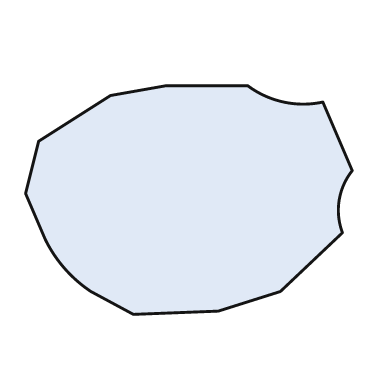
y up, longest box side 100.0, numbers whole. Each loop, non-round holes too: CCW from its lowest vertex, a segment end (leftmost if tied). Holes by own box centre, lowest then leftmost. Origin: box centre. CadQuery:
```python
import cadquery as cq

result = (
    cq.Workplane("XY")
    .moveTo(-17.0, -35.0)
    .lineTo(9.0, -34.0)
    .lineTo(28.0, -28.0)
    .lineTo(47.0, -10.0)
    .threePointArc((46.0, 0.0), (50.0, 9.0))
    .lineTo(41.0, 30.0)
    .threePointArc((29.0, 30.0), (18.0, 35.0))
    .lineTo(-7.0, 35.0)
    .lineTo(-24.0, 32.0)
    .lineTo(-46.0, 18.0)
    .lineTo(-50.0, 2.0)
    .lineTo(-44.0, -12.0)
    .threePointArc((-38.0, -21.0), (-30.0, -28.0))
    .close()
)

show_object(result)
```